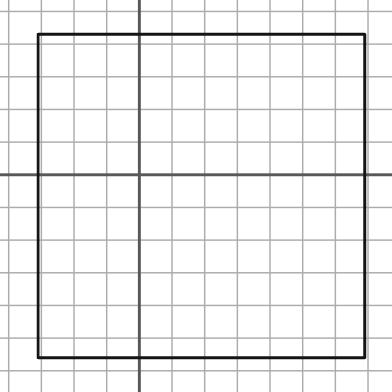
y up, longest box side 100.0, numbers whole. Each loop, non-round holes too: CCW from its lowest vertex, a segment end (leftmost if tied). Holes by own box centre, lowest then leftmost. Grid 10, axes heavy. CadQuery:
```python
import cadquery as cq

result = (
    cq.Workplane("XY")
    .moveTo(-31.0, -56.0)
    .lineTo(69.0, -56.0)
    .lineTo(69.0, 43.0)
    .lineTo(-31.0, 43.0)
    .close()
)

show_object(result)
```